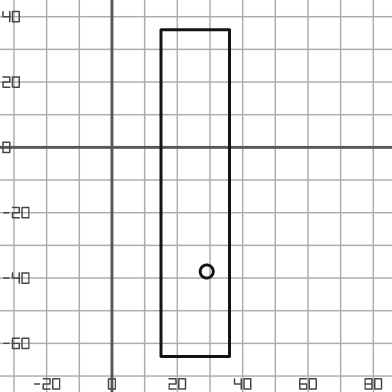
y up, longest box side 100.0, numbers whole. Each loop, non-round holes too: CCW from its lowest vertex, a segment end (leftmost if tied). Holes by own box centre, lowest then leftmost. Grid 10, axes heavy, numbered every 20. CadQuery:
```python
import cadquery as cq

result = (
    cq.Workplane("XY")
    .moveTo(15.0, -64.0)
    .lineTo(36.0, -64.0)
    .lineTo(36.0, 36.0)
    .lineTo(15.0, 36.0)
    .close()
    .moveTo(29.0, -38.0)
    .circle(2.0)
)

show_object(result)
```